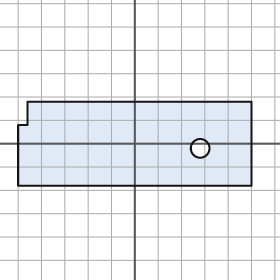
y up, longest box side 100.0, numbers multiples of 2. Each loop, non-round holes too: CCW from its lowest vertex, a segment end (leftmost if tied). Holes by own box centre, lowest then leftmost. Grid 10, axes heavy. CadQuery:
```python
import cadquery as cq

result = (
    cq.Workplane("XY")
    .moveTo(-50.0, -18.0)
    .lineTo(50.0, -18.0)
    .lineTo(50.0, 18.0)
    .lineTo(-46.0, 18.0)
    .lineTo(-46.0, 8.0)
    .lineTo(-50.0, 8.0)
    .close()
    .moveTo(28.0, -2.0)
    .circle(4.0)
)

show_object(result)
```